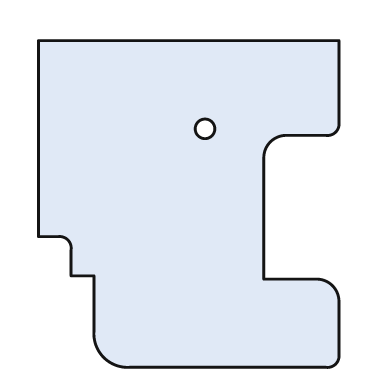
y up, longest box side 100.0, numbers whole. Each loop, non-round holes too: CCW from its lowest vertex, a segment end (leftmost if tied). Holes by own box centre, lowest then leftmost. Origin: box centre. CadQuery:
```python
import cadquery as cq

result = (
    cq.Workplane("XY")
    .moveTo(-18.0, -50.0)
    .lineTo(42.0, -50.0)
    .threePointArc((45.0, -49.0), (46.0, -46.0))
    .lineTo(46.0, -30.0)
    .threePointArc((44.0, -25.0), (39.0, -23.0))
    .lineTo(23.0, -23.0)
    .lineTo(23.0, 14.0)
    .threePointArc((25.0, 19.0), (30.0, 21.0))
    .lineTo(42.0, 21.0)
    .threePointArc((45.0, 22.0), (46.0, 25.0))
    .lineTo(46.0, 50.0)
    .lineTo(-46.0, 50.0)
    .lineTo(-46.0, -10.0)
    .lineTo(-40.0, -10.0)
    .threePointArc((-37.0, -11.0), (-36.0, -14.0))
    .lineTo(-36.0, -22.0)
    .lineTo(-29.0, -22.0)
    .lineTo(-29.0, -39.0)
    .threePointArc((-26.0, -47.0), (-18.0, -50.0))
    .close()
    .moveTo(5.0, 23.0)
    .circle(3.0)
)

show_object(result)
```